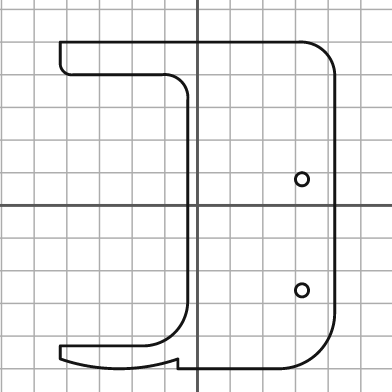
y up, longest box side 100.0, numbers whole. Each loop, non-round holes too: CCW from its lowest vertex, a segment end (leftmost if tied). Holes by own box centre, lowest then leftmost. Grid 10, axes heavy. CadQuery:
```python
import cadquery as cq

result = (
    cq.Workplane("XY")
    .moveTo(-6.0, -50.0)
    .lineTo(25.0, -50.0)
    .threePointArc((37.0, -45.0), (42.0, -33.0))
    .lineTo(42.0, 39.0)
    .threePointArc((39.0, 47.0), (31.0, 50.0))
    .lineTo(-42.0, 50.0)
    .lineTo(-42.0, 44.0)
    .threePointArc((-41.0, 41.0), (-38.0, 40.0))
    .lineTo(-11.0, 40.0)
    .threePointArc((-5.0, 38.0), (-3.0, 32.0))
    .lineTo(-3.0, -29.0)
    .threePointArc((-7.0, -39.0), (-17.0, -43.0))
    .lineTo(-42.0, -43.0)
    .lineTo(-42.0, -47.0)
    .threePointArc((-24.0, -50.0), (-6.0, -47.0))
    .close()
    .moveTo(32.0, -26.0)
    .circle(2.0)
    .moveTo(32.0, 8.0)
    .circle(2.0)
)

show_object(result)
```